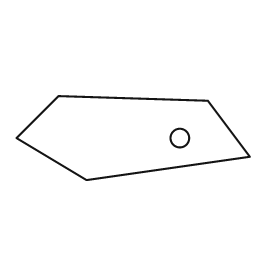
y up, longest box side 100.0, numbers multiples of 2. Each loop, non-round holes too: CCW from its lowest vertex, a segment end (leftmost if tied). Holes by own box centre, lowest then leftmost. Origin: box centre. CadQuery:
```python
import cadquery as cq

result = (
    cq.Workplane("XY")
    .moveTo(-20.0, -18.0)
    .lineTo(50.0, -8.0)
    .lineTo(32.0, 16.0)
    .lineTo(-32.0, 18.0)
    .lineTo(-50.0, 0.0)
    .close()
    .moveTo(20.0, 0.0)
    .circle(4.0)
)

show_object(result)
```